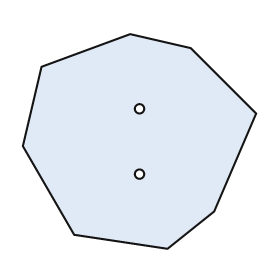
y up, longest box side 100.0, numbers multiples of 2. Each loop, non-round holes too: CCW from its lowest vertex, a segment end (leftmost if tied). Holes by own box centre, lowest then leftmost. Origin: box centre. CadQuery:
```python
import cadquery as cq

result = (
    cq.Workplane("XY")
    .moveTo(12.0, -46.0)
    .lineTo(32.0, -30.0)
    .lineTo(50.0, 12.0)
    .lineTo(22.0, 40.0)
    .lineTo(-4.0, 46.0)
    .lineTo(-42.0, 32.0)
    .lineTo(-50.0, -2.0)
    .lineTo(-28.0, -40.0)
    .close()
    .moveTo(0.0, -14.0)
    .circle(2.0)
    .moveTo(0.0, 14.0)
    .circle(2.0)
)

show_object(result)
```